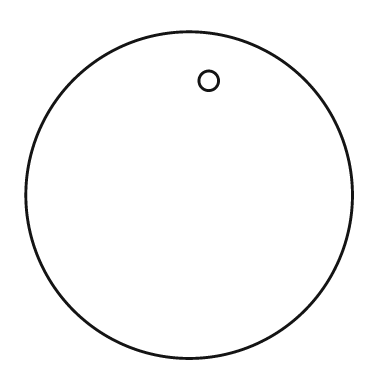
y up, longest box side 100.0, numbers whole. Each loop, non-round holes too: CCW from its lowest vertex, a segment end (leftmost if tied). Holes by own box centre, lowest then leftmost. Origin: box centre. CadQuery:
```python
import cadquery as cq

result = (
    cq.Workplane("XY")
    .moveTo(0.0, 0.0)
    .circle(50.0)
    .moveTo(6.0, 35.0)
    .circle(3.0)
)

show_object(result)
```